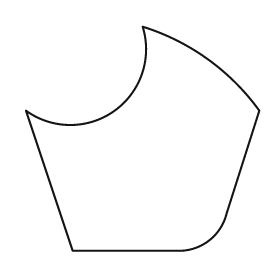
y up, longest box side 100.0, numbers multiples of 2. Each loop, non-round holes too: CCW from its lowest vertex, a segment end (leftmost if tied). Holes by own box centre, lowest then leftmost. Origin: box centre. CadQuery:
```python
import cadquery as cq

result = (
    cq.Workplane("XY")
    .moveTo(-30.0, -48.0)
    .lineTo(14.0, -48.0)
    .threePointArc((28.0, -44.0), (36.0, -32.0))
    .lineTo(50.0, 12.0)
    .threePointArc((28.0, 34.0), (0.0, 48.0))
    .threePointArc((-12.0, 12.0), (-50.0, 12.0))
    .close()
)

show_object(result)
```